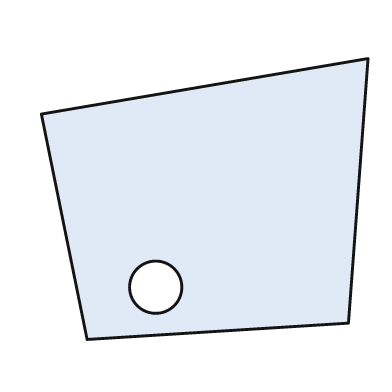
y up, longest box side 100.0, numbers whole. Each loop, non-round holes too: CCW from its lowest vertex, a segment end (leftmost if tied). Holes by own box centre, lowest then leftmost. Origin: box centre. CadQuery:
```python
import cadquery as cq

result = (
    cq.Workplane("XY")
    .moveTo(-36.0, -43.0)
    .lineTo(44.0, -38.0)
    .lineTo(50.0, 43.0)
    .lineTo(-50.0, 26.0)
    .close()
    .moveTo(-15.0, -27.0)
    .circle(8.0)
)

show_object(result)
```